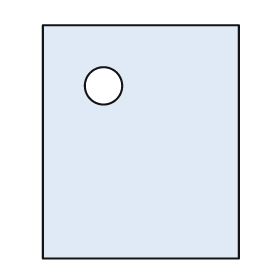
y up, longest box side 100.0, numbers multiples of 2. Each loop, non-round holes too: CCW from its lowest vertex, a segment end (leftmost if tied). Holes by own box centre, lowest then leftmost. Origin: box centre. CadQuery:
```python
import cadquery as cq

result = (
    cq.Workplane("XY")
    .moveTo(-42.0, -50.0)
    .lineTo(42.0, -50.0)
    .lineTo(42.0, 50.0)
    .lineTo(-42.0, 50.0)
    .close()
    .moveTo(-16.0, 24.0)
    .circle(8.0)
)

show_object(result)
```